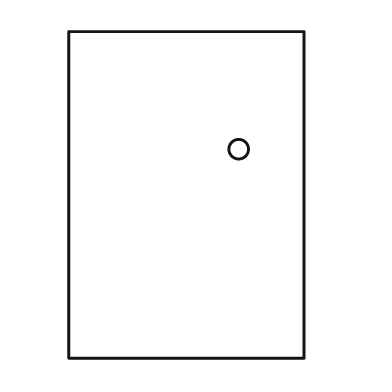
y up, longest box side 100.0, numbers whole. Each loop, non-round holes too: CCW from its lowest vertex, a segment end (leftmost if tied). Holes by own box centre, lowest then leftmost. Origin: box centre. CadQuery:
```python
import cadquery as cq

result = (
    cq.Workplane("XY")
    .moveTo(-36.0, -50.0)
    .lineTo(36.0, -50.0)
    .lineTo(36.0, 50.0)
    .lineTo(-36.0, 50.0)
    .close()
    .moveTo(16.0, 14.0)
    .circle(3.0)
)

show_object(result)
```